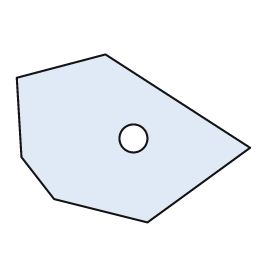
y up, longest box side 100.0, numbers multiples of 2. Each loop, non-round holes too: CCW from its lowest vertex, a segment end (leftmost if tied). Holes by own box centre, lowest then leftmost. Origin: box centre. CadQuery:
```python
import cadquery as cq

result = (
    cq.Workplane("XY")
    .moveTo(6.0, -36.0)
    .lineTo(50.0, -4.0)
    .lineTo(-12.0, 36.0)
    .lineTo(-50.0, 26.0)
    .lineTo(-48.0, -8.0)
    .lineTo(-34.0, -26.0)
    .close()
    .moveTo(0.0, 0.0)
    .circle(6.0)
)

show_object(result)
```